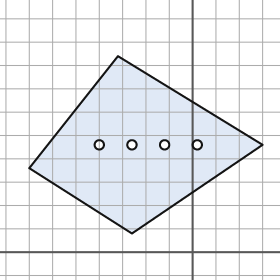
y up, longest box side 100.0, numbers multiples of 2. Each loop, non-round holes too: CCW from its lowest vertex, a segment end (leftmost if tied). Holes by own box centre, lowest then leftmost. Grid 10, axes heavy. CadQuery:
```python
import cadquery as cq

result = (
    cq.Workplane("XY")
    .moveTo(-26.0, 8.0)
    .lineTo(30.0, 46.0)
    .lineTo(-32.0, 84.0)
    .lineTo(-70.0, 36.0)
    .close()
    .moveTo(-40.0, 46.0)
    .circle(2.0)
    .moveTo(-26.0, 46.0)
    .circle(2.0)
    .moveTo(-12.0, 46.0)
    .circle(2.0)
    .moveTo(2.0, 46.0)
    .circle(2.0)
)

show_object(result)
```